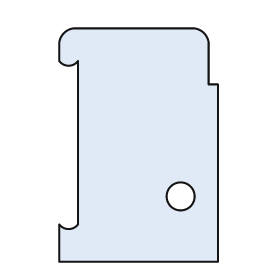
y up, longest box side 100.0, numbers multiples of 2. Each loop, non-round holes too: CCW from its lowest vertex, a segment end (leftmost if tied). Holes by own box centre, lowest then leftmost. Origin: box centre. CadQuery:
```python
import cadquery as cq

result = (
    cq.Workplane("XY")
    .moveTo(-34.0, -50.0)
    .lineTo(34.0, -50.0)
    .lineTo(34.0, 26.0)
    .lineTo(30.0, 26.0)
    .lineTo(30.0, 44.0)
    .threePointArc((28.0, 48.0), (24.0, 50.0))
    .lineTo(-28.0, 50.0)
    .threePointArc((-32.0, 48.0), (-34.0, 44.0))
    .lineTo(-34.0, 36.0)
    .threePointArc((-30.0, 34.0), (-26.0, 36.0))
    .lineTo(-26.0, -34.0)
    .threePointArc((-30.0, -36.0), (-34.0, -34.0))
    .close()
    .moveTo(18.0, -22.0)
    .circle(6.0)
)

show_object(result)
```